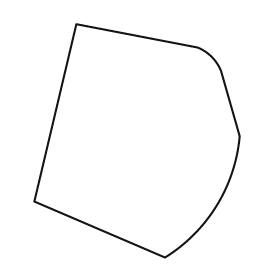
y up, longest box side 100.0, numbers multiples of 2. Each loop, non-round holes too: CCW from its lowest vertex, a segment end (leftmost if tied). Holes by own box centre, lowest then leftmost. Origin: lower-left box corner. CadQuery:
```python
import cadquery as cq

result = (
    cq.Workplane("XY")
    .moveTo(56.0, 0.0)
    .threePointArc((78.0, 22.0), (88.0, 52.0))
    .lineTo(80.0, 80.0)
    .threePointArc((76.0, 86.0), (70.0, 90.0))
    .lineTo(18.0, 100.0)
    .lineTo(0.0, 24.0)
    .close()
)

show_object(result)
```